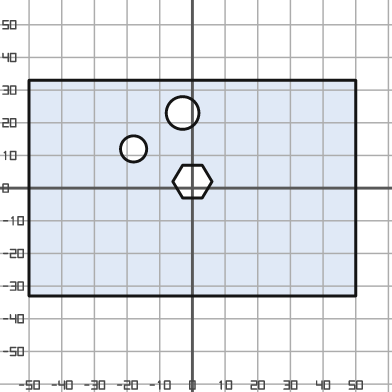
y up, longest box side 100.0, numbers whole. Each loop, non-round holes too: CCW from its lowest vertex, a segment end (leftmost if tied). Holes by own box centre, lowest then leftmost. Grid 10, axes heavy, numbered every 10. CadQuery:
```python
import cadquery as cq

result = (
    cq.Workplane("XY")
    .moveTo(-50.0, -33.0)
    .lineTo(50.0, -33.0)
    .lineTo(50.0, 33.0)
    .lineTo(-50.0, 33.0)
    .close()
    .moveTo(-3.0, -3.0)
    .lineTo(3.0, -3.0)
    .lineTo(6.0, 2.0)
    .lineTo(3.0, 7.0)
    .lineTo(-3.0, 7.0)
    .lineTo(-6.0, 2.0)
    .close()
    .moveTo(-18.0, 12.0)
    .circle(4.0)
    .moveTo(-3.0, 23.0)
    .circle(5.0)
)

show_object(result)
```